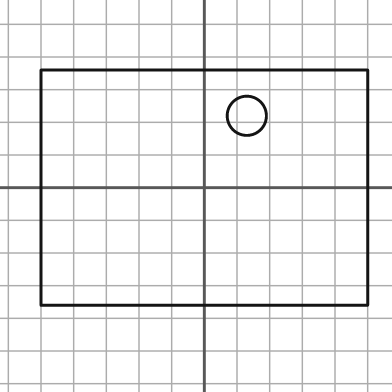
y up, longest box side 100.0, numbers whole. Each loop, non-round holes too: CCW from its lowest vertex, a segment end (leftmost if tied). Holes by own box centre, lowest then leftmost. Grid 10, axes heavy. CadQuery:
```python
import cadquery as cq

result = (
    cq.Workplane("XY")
    .moveTo(-50.0, -36.0)
    .lineTo(50.0, -36.0)
    .lineTo(50.0, 36.0)
    .lineTo(-50.0, 36.0)
    .close()
    .moveTo(13.0, 22.0)
    .circle(6.0)
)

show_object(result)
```